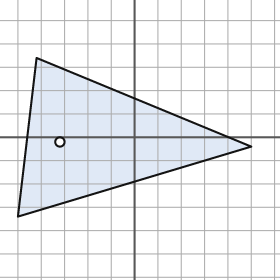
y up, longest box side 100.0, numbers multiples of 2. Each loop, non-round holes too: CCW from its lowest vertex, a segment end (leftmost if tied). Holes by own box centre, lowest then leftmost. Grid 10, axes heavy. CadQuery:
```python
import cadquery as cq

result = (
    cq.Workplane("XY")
    .moveTo(-50.0, -34.0)
    .lineTo(50.0, -4.0)
    .lineTo(-42.0, 34.0)
    .close()
    .moveTo(-32.0, -2.0)
    .circle(2.0)
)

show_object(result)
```